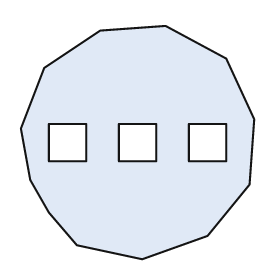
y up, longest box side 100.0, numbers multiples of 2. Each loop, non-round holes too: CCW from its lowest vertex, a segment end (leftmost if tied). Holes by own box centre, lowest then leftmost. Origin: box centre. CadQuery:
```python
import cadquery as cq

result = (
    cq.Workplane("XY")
    .moveTo(2.0, -50.0)
    .lineTo(30.0, -40.0)
    .lineTo(48.0, -18.0)
    .lineTo(50.0, 10.0)
    .lineTo(38.0, 36.0)
    .lineTo(12.0, 50.0)
    .lineTo(-16.0, 48.0)
    .lineTo(-40.0, 32.0)
    .lineTo(-50.0, 6.0)
    .lineTo(-46.0, -16.0)
    .lineTo(-38.0, -30.0)
    .lineTo(-26.0, -44.0)
    .close()
    .moveTo(-38.0, -8.0)
    .lineTo(-22.0, -8.0)
    .lineTo(-22.0, 8.0)
    .lineTo(-38.0, 8.0)
    .close()
    .moveTo(-8.0, -8.0)
    .lineTo(8.0, -8.0)
    .lineTo(8.0, 8.0)
    .lineTo(-8.0, 8.0)
    .close()
    .moveTo(22.0, -8.0)
    .lineTo(38.0, -8.0)
    .lineTo(38.0, 8.0)
    .lineTo(22.0, 8.0)
    .close()
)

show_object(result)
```